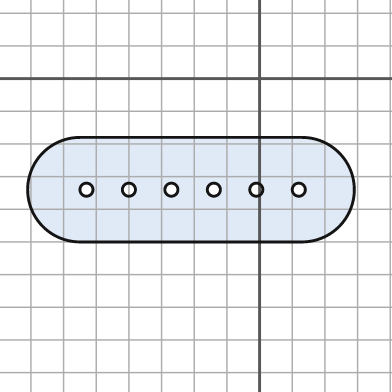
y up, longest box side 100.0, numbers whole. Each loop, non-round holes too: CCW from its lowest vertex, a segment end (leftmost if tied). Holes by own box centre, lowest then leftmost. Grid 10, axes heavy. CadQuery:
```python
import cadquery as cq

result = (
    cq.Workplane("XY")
    .moveTo(-55.0, -50.0)
    .lineTo(13.0, -50.0)
    .threePointArc((29.0, -34.0), (13.0, -18.0))
    .lineTo(-55.0, -18.0)
    .threePointArc((-71.0, -34.0), (-55.0, -50.0))
    .close()
    .moveTo(-53.0, -34.0)
    .circle(2.0)
    .moveTo(-40.0, -34.0)
    .circle(2.0)
    .moveTo(-27.0, -34.0)
    .circle(2.0)
    .moveTo(-14.0, -34.0)
    .circle(2.0)
    .moveTo(-1.0, -34.0)
    .circle(2.0)
    .moveTo(12.0, -34.0)
    .circle(2.0)
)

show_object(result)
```